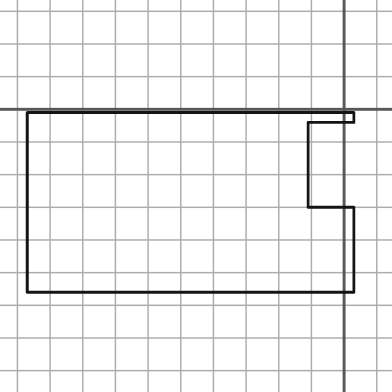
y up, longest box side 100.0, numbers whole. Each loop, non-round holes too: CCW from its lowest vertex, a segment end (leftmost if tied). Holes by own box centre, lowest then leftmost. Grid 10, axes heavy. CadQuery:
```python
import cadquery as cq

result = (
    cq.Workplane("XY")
    .moveTo(-97.0, -56.0)
    .lineTo(3.0, -56.0)
    .lineTo(3.0, -30.0)
    .lineTo(-11.0, -30.0)
    .lineTo(-11.0, -4.0)
    .lineTo(3.0, -4.0)
    .lineTo(3.0, -1.0)
    .lineTo(-97.0, -1.0)
    .close()
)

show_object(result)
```